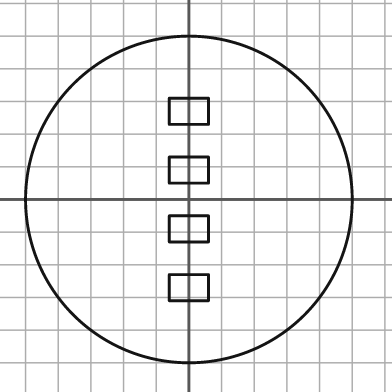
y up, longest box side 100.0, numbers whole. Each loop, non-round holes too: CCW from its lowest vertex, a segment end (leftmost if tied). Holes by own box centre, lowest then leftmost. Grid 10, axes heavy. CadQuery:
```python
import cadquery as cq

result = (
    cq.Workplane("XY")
    .moveTo(0.0, 0.0)
    .circle(50.0)
    .moveTo(-6.0, -31.0)
    .lineTo(6.0, -31.0)
    .lineTo(6.0, -23.0)
    .lineTo(-6.0, -23.0)
    .close()
    .moveTo(-6.0, -13.0)
    .lineTo(6.0, -13.0)
    .lineTo(6.0, -5.0)
    .lineTo(-6.0, -5.0)
    .close()
    .moveTo(-6.0, 5.0)
    .lineTo(6.0, 5.0)
    .lineTo(6.0, 13.0)
    .lineTo(-6.0, 13.0)
    .close()
    .moveTo(-6.0, 23.0)
    .lineTo(6.0, 23.0)
    .lineTo(6.0, 31.0)
    .lineTo(-6.0, 31.0)
    .close()
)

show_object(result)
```